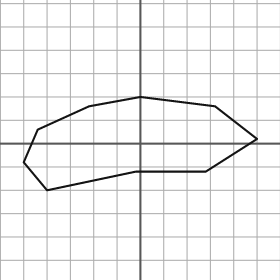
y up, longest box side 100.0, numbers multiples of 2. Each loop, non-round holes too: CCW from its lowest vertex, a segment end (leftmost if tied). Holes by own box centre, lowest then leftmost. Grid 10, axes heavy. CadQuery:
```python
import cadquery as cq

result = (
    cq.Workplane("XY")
    .moveTo(-40.0, -20.0)
    .lineTo(-2.0, -12.0)
    .lineTo(28.0, -12.0)
    .lineTo(50.0, 2.0)
    .lineTo(32.0, 16.0)
    .lineTo(0.0, 20.0)
    .lineTo(-22.0, 16.0)
    .lineTo(-44.0, 6.0)
    .lineTo(-50.0, -8.0)
    .close()
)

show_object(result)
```